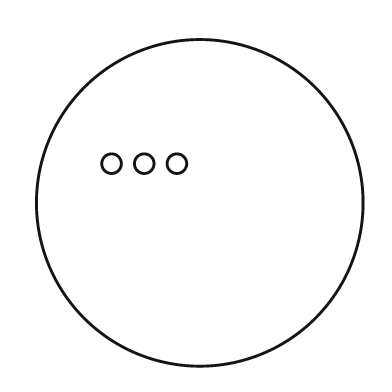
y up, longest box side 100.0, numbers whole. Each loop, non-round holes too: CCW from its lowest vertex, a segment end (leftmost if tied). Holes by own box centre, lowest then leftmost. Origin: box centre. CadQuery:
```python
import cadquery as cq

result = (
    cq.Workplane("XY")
    .moveTo(0.0, 0.0)
    .circle(50.0)
    .moveTo(-27.0, 12.0)
    .circle(3.0)
    .moveTo(-17.0, 12.0)
    .circle(3.0)
    .moveTo(-7.0, 12.0)
    .circle(3.0)
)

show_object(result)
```